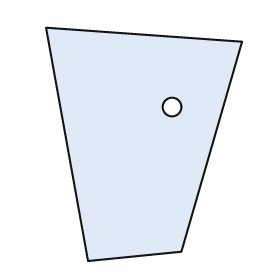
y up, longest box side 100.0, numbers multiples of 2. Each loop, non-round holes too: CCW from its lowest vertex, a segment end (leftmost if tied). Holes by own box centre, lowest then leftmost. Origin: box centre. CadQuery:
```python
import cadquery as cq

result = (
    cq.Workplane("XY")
    .moveTo(-24.0, -50.0)
    .lineTo(16.0, -46.0)
    .lineTo(42.0, 44.0)
    .lineTo(-42.0, 50.0)
    .close()
    .moveTo(12.0, 16.0)
    .circle(4.0)
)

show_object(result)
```